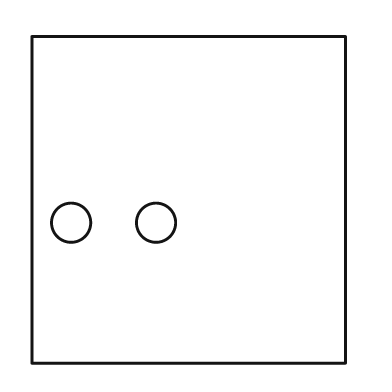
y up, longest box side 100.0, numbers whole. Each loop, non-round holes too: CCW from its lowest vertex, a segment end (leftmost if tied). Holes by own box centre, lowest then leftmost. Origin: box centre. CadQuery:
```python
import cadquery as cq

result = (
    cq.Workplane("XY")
    .moveTo(-48.0, -50.0)
    .lineTo(48.0, -50.0)
    .lineTo(48.0, 50.0)
    .lineTo(-48.0, 50.0)
    .close()
    .moveTo(-36.0, -7.0)
    .circle(6.0)
    .moveTo(-10.0, -7.0)
    .circle(6.0)
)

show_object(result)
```